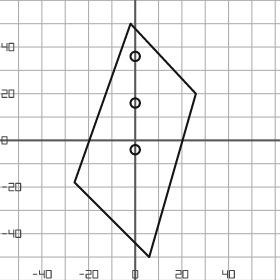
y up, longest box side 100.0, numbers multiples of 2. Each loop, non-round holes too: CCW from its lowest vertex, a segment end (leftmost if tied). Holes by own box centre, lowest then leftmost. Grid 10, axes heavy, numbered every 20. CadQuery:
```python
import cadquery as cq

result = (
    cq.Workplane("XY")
    .moveTo(6.0, -50.0)
    .lineTo(26.0, 20.0)
    .lineTo(-2.0, 50.0)
    .lineTo(-26.0, -18.0)
    .close()
    .moveTo(0.0, -4.0)
    .circle(2.0)
    .moveTo(0.0, 16.0)
    .circle(2.0)
    .moveTo(0.0, 36.0)
    .circle(2.0)
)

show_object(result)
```